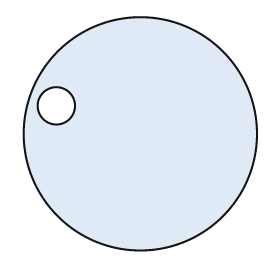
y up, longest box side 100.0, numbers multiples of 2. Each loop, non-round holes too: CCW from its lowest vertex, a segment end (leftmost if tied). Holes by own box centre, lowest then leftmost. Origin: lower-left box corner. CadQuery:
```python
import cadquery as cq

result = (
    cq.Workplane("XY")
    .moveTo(50.0, 50.0)
    .circle(50.0)
    .moveTo(14.0, 62.0)
    .circle(8.0)
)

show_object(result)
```